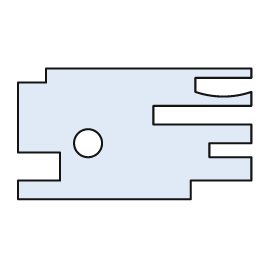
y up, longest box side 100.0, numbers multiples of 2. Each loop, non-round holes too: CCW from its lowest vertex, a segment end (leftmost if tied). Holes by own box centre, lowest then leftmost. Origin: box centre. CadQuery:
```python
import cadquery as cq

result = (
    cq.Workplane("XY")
    .moveTo(-50.0, -28.0)
    .lineTo(24.0, -28.0)
    .lineTo(24.0, -20.0)
    .lineTo(50.0, -20.0)
    .lineTo(50.0, -10.0)
    .lineTo(32.0, -10.0)
    .lineTo(32.0, -4.0)
    .lineTo(50.0, -4.0)
    .lineTo(50.0, 4.0)
    .lineTo(8.0, 4.0)
    .lineTo(8.0, 12.0)
    .lineTo(50.0, 12.0)
    .lineTo(50.0, 18.0)
    .threePointArc((38.0, 16.0), (26.0, 18.0))
    .lineTo(26.0, 24.0)
    .lineTo(50.0, 24.0)
    .lineTo(50.0, 28.0)
    .lineTo(-38.0, 28.0)
    .lineTo(-38.0, 22.0)
    .lineTo(-50.0, 22.0)
    .lineTo(-50.0, -8.0)
    .lineTo(-32.0, -8.0)
    .lineTo(-32.0, -20.0)
    .lineTo(-50.0, -20.0)
    .close()
    .moveTo(-20.0, -4.0)
    .circle(6.0)
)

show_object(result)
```